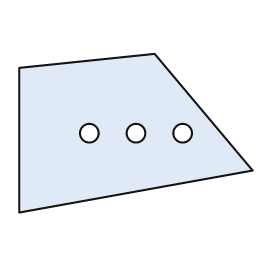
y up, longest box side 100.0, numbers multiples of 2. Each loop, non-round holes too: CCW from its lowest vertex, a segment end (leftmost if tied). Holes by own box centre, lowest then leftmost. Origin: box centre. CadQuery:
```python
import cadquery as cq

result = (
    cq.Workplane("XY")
    .moveTo(-50.0, -34.0)
    .lineTo(50.0, -16.0)
    .lineTo(8.0, 34.0)
    .lineTo(-50.0, 28.0)
    .close()
    .moveTo(-20.0, 0.0)
    .circle(4.0)
    .moveTo(0.0, 0.0)
    .circle(4.0)
    .moveTo(20.0, 0.0)
    .circle(4.0)
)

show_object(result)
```